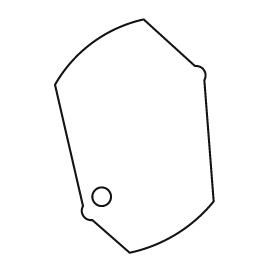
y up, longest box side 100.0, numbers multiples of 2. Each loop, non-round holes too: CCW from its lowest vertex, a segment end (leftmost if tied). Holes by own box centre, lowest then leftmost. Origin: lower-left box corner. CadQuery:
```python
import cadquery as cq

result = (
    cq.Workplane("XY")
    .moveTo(32.0, 0.0)
    .threePointArc((52.0, 8.0), (68.0, 22.0))
    .lineTo(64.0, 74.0)
    .threePointArc((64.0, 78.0), (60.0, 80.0))
    .lineTo(38.0, 100.0)
    .threePointArc((16.0, 90.0), (0.0, 72.0))
    .lineTo(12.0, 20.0)
    .threePointArc((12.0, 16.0), (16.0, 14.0))
    .close()
    .moveTo(20.0, 24.0)
    .circle(4.0)
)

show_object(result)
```